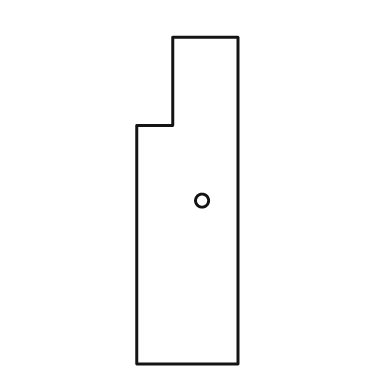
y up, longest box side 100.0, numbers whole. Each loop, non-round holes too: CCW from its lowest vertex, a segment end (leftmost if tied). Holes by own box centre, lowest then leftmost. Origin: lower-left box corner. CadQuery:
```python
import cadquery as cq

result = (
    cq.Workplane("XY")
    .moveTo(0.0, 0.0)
    .lineTo(31.0, 0.0)
    .lineTo(31.0, 100.0)
    .lineTo(11.0, 100.0)
    .lineTo(11.0, 73.0)
    .lineTo(0.0, 73.0)
    .close()
    .moveTo(20.0, 50.0)
    .circle(2.0)
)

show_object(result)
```